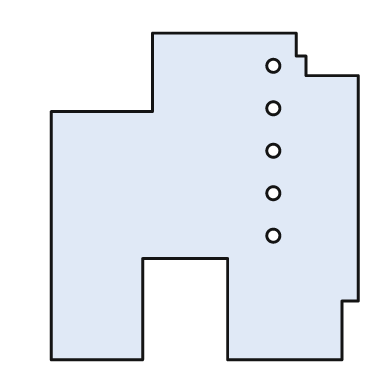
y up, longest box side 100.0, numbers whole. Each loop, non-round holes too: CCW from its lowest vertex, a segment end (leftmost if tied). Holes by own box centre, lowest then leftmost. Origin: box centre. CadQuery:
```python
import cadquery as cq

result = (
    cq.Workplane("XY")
    .moveTo(-47.0, -50.0)
    .lineTo(-19.0, -50.0)
    .lineTo(-19.0, -19.0)
    .lineTo(7.0, -19.0)
    .lineTo(7.0, -50.0)
    .lineTo(42.0, -50.0)
    .lineTo(42.0, -32.0)
    .lineTo(47.0, -32.0)
    .lineTo(47.0, 37.0)
    .lineTo(31.0, 37.0)
    .lineTo(31.0, 43.0)
    .lineTo(28.0, 43.0)
    .lineTo(28.0, 50.0)
    .lineTo(-16.0, 50.0)
    .lineTo(-16.0, 26.0)
    .lineTo(-47.0, 26.0)
    .close()
    .moveTo(21.0, -12.0)
    .circle(2.0)
    .moveTo(21.0, 1.0)
    .circle(2.0)
    .moveTo(21.0, 14.0)
    .circle(2.0)
    .moveTo(21.0, 27.0)
    .circle(2.0)
    .moveTo(21.0, 40.0)
    .circle(2.0)
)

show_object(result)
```